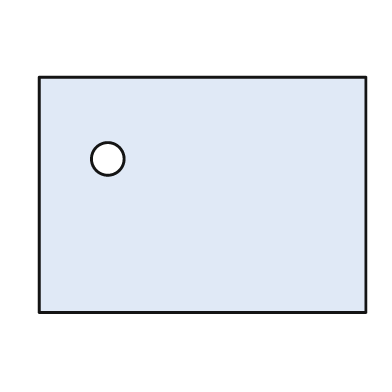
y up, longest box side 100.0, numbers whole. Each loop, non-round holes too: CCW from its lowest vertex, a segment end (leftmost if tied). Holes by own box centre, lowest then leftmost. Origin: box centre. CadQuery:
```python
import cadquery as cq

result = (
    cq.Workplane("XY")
    .moveTo(-50.0, -36.0)
    .lineTo(50.0, -36.0)
    .lineTo(50.0, 36.0)
    .lineTo(-50.0, 36.0)
    .close()
    .moveTo(-29.0, 11.0)
    .circle(5.0)
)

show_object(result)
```